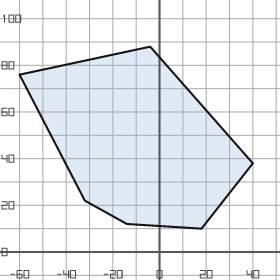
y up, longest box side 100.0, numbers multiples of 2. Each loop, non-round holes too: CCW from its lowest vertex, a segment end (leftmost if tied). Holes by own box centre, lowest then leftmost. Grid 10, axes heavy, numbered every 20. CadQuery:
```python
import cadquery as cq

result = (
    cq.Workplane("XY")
    .moveTo(18.0, 10.0)
    .lineTo(40.0, 38.0)
    .lineTo(-4.0, 88.0)
    .lineTo(-60.0, 76.0)
    .lineTo(-32.0, 22.0)
    .lineTo(-14.0, 12.0)
    .close()
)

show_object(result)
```